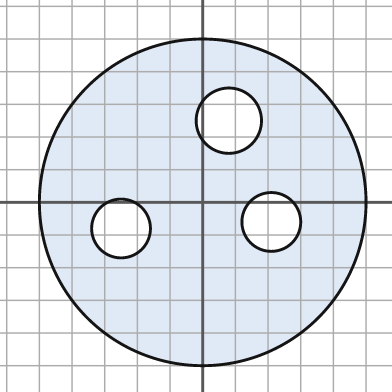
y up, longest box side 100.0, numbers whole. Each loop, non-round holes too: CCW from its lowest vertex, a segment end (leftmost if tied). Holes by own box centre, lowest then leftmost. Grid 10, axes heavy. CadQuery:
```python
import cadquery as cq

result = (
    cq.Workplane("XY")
    .moveTo(0.0, 0.0)
    .circle(50.0)
    .moveTo(-25.0, -8.0)
    .circle(9.0)
    .moveTo(21.0, -6.0)
    .circle(9.0)
    .moveTo(8.0, 25.0)
    .circle(10.0)
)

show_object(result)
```